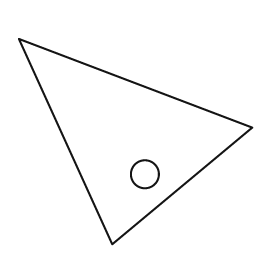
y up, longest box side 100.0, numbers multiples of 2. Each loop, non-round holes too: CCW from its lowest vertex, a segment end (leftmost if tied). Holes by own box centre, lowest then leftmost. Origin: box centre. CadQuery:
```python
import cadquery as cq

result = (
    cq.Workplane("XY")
    .moveTo(-10.0, -44.0)
    .lineTo(50.0, 6.0)
    .lineTo(-50.0, 44.0)
    .close()
    .moveTo(4.0, -14.0)
    .circle(6.0)
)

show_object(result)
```